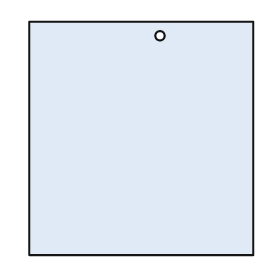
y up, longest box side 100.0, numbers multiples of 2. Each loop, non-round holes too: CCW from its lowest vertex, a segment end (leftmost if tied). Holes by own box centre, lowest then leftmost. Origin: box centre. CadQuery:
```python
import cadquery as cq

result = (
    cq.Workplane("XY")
    .moveTo(-48.0, -50.0)
    .lineTo(48.0, -50.0)
    .lineTo(48.0, 50.0)
    .lineTo(-48.0, 50.0)
    .close()
    .moveTo(8.0, 44.0)
    .circle(2.0)
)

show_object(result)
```